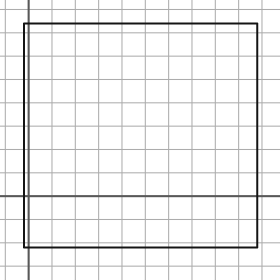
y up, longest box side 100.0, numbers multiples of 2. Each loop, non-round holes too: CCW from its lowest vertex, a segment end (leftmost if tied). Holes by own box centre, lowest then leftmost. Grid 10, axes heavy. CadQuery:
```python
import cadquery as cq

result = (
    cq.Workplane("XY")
    .moveTo(-2.0, -22.0)
    .lineTo(98.0, -22.0)
    .lineTo(98.0, 74.0)
    .lineTo(-2.0, 74.0)
    .close()
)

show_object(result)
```